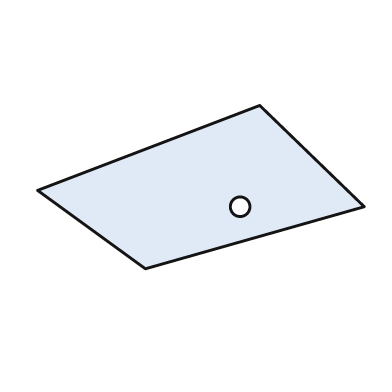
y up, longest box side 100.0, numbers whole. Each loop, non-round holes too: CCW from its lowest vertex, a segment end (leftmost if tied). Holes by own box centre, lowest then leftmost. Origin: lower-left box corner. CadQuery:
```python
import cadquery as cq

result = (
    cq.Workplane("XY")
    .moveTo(33.0, 0.0)
    .lineTo(100.0, 19.0)
    .lineTo(68.0, 50.0)
    .lineTo(0.0, 24.0)
    .close()
    .moveTo(62.0, 19.0)
    .circle(3.0)
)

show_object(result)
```